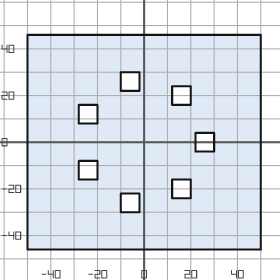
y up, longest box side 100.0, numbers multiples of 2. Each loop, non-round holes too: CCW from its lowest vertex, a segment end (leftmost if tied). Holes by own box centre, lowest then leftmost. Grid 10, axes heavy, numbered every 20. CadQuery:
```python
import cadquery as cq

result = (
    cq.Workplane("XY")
    .moveTo(-50.0, -46.0)
    .lineTo(50.0, -46.0)
    .lineTo(50.0, 46.0)
    .lineTo(-50.0, 46.0)
    .close()
    .moveTo(-10.0, -30.0)
    .lineTo(-2.0, -30.0)
    .lineTo(-2.0, -22.0)
    .lineTo(-10.0, -22.0)
    .close()
    .moveTo(12.0, -24.0)
    .lineTo(20.0, -24.0)
    .lineTo(20.0, -16.0)
    .lineTo(12.0, -16.0)
    .close()
    .moveTo(-28.0, -16.0)
    .lineTo(-20.0, -16.0)
    .lineTo(-20.0, -8.0)
    .lineTo(-28.0, -8.0)
    .close()
    .moveTo(22.0, -4.0)
    .lineTo(30.0, -4.0)
    .lineTo(30.0, 4.0)
    .lineTo(22.0, 4.0)
    .close()
    .moveTo(-28.0, 8.0)
    .lineTo(-20.0, 8.0)
    .lineTo(-20.0, 16.0)
    .lineTo(-28.0, 16.0)
    .close()
    .moveTo(12.0, 16.0)
    .lineTo(20.0, 16.0)
    .lineTo(20.0, 24.0)
    .lineTo(12.0, 24.0)
    .close()
    .moveTo(-10.0, 22.0)
    .lineTo(-2.0, 22.0)
    .lineTo(-2.0, 30.0)
    .lineTo(-10.0, 30.0)
    .close()
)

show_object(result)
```